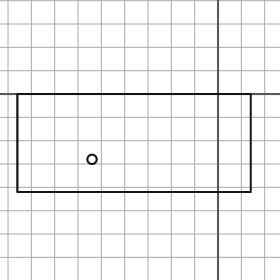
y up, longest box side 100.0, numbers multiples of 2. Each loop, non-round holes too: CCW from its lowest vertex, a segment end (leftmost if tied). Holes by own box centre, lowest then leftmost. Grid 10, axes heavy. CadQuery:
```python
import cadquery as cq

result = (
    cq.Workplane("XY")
    .moveTo(-86.0, -42.0)
    .lineTo(14.0, -42.0)
    .lineTo(14.0, 0.0)
    .lineTo(-86.0, 0.0)
    .close()
    .moveTo(-54.0, -28.0)
    .circle(2.0)
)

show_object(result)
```